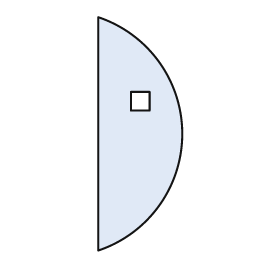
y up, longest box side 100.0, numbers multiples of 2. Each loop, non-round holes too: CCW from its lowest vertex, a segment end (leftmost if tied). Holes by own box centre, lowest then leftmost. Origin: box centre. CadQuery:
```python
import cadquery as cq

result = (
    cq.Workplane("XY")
    .moveTo(-18.0, -50.0)
    .threePointArc((18.0, 0.0), (-18.0, 50.0))
    .close()
    .moveTo(-4.0, 10.0)
    .lineTo(4.0, 10.0)
    .lineTo(4.0, 18.0)
    .lineTo(-4.0, 18.0)
    .close()
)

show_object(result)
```